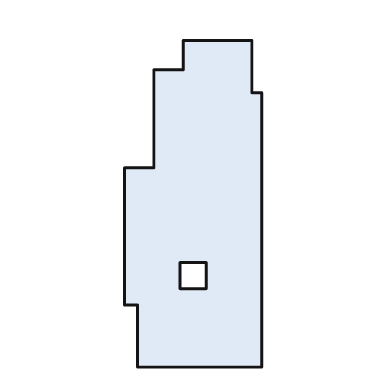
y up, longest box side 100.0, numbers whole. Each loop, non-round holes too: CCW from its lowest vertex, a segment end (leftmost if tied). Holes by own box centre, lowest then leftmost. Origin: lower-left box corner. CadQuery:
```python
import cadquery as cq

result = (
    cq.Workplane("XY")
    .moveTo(4.0, 0.0)
    .lineTo(42.0, 0.0)
    .lineTo(42.0, 84.0)
    .lineTo(39.0, 84.0)
    .lineTo(39.0, 100.0)
    .lineTo(18.0, 100.0)
    .lineTo(18.0, 91.0)
    .lineTo(9.0, 91.0)
    .lineTo(9.0, 61.0)
    .lineTo(0.0, 61.0)
    .lineTo(0.0, 19.0)
    .lineTo(4.0, 19.0)
    .close()
    .moveTo(17.0, 24.0)
    .lineTo(25.0, 24.0)
    .lineTo(25.0, 32.0)
    .lineTo(17.0, 32.0)
    .close()
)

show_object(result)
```